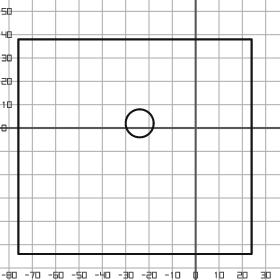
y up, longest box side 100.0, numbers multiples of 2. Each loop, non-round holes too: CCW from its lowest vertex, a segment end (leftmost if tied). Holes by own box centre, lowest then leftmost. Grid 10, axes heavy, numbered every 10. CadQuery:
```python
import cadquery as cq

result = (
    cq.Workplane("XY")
    .moveTo(-76.0, -54.0)
    .lineTo(24.0, -54.0)
    .lineTo(24.0, 38.0)
    .lineTo(-76.0, 38.0)
    .close()
    .moveTo(-24.0, 2.0)
    .circle(6.0)
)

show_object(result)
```